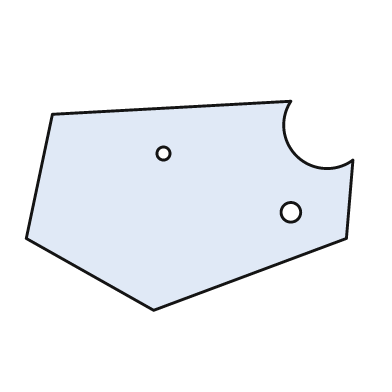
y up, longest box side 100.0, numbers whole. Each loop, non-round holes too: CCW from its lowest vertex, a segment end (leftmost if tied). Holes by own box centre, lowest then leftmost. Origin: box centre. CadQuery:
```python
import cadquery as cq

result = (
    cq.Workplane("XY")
    .moveTo(-11.0, -32.0)
    .lineTo(48.0, -10.0)
    .lineTo(50.0, 14.0)
    .threePointArc((33.0, 15.0), (31.0, 32.0))
    .lineTo(-42.0, 28.0)
    .lineTo(-50.0, -10.0)
    .close()
    .moveTo(31.0, -2.0)
    .circle(3.0)
    .moveTo(-8.0, 16.0)
    .circle(2.0)
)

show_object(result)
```